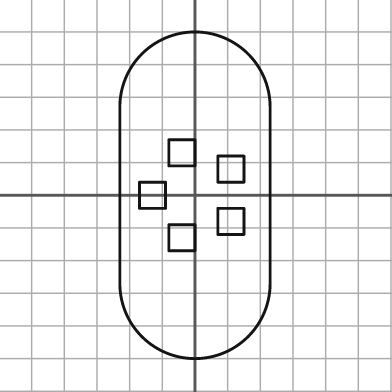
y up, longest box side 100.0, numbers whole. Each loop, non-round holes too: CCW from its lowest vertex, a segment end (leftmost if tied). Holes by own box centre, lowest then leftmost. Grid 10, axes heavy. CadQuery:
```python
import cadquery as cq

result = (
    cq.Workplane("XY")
    .moveTo(-23.0, -27.0)
    .threePointArc((0.0, -50.0), (23.0, -27.0))
    .lineTo(23.0, 27.0)
    .threePointArc((0.0, 50.0), (-23.0, 27.0))
    .close()
    .moveTo(-8.0, -17.0)
    .lineTo(0.0, -17.0)
    .lineTo(0.0, -9.0)
    .lineTo(-8.0, -9.0)
    .close()
    .moveTo(7.0, -12.0)
    .lineTo(15.0, -12.0)
    .lineTo(15.0, -4.0)
    .lineTo(7.0, -4.0)
    .close()
    .moveTo(-17.0, -4.0)
    .lineTo(-9.0, -4.0)
    .lineTo(-9.0, 4.0)
    .lineTo(-17.0, 4.0)
    .close()
    .moveTo(7.0, 4.0)
    .lineTo(15.0, 4.0)
    .lineTo(15.0, 12.0)
    .lineTo(7.0, 12.0)
    .close()
    .moveTo(-8.0, 9.0)
    .lineTo(0.0, 9.0)
    .lineTo(0.0, 17.0)
    .lineTo(-8.0, 17.0)
    .close()
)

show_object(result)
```